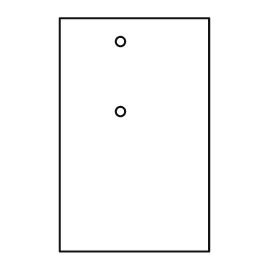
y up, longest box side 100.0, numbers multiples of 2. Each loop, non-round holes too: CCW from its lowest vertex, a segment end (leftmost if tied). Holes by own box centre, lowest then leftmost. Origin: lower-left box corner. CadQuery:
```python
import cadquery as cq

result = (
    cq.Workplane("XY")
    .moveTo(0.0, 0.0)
    .lineTo(64.0, 0.0)
    .lineTo(64.0, 100.0)
    .lineTo(0.0, 100.0)
    .close()
    .moveTo(26.0, 60.0)
    .circle(2.0)
    .moveTo(26.0, 90.0)
    .circle(2.0)
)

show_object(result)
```